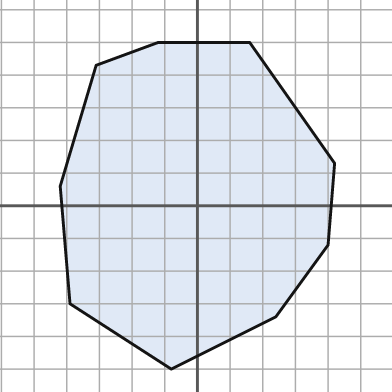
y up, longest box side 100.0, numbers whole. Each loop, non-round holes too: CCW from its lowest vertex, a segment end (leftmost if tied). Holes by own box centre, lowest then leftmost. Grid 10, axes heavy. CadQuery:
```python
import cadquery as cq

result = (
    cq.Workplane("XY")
    .moveTo(-8.0, -50.0)
    .lineTo(24.0, -34.0)
    .lineTo(40.0, -12.0)
    .lineTo(42.0, 13.0)
    .lineTo(16.0, 50.0)
    .lineTo(-12.0, 50.0)
    .lineTo(-31.0, 43.0)
    .lineTo(-42.0, 6.0)
    .lineTo(-39.0, -30.0)
    .close()
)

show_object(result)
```